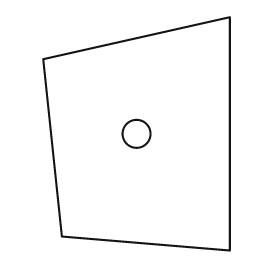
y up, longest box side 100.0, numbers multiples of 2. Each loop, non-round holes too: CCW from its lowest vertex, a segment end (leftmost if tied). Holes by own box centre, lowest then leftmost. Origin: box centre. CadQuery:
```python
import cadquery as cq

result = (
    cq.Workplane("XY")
    .moveTo(40.0, -50.0)
    .lineTo(40.0, 50.0)
    .lineTo(-40.0, 32.0)
    .lineTo(-32.0, -44.0)
    .close()
    .moveTo(0.0, 0.0)
    .circle(6.0)
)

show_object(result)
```